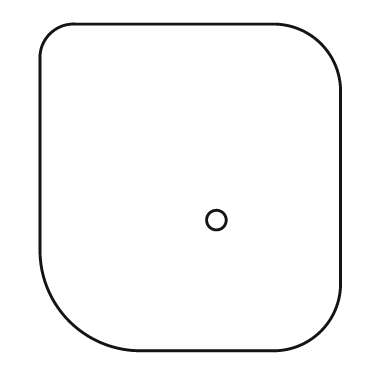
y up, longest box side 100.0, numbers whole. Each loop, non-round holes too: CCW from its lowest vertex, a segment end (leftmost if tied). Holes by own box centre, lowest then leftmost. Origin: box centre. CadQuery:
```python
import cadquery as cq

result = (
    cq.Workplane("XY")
    .moveTo(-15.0, -50.0)
    .lineTo(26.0, -50.0)
    .threePointArc((40.0, -44.0), (46.0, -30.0))
    .lineTo(46.0, 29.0)
    .threePointArc((40.0, 44.0), (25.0, 50.0))
    .lineTo(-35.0, 50.0)
    .threePointArc((-43.0, 47.0), (-46.0, 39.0))
    .lineTo(-46.0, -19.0)
    .threePointArc((-37.0, -41.0), (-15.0, -50.0))
    .close()
    .moveTo(8.0, -10.0)
    .circle(3.0)
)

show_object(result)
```